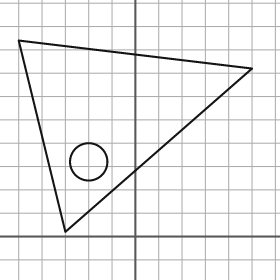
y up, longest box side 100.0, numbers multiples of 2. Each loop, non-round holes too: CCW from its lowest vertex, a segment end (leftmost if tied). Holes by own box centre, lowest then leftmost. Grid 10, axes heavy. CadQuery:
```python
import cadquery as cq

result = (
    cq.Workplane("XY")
    .moveTo(-30.0, 2.0)
    .lineTo(50.0, 72.0)
    .lineTo(-50.0, 84.0)
    .close()
    .moveTo(-20.0, 32.0)
    .circle(8.0)
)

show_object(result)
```